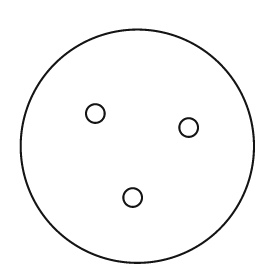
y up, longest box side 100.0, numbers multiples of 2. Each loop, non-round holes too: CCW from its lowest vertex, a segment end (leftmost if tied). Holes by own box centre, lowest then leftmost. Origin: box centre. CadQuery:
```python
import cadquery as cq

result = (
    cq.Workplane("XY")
    .moveTo(0.0, 0.0)
    .circle(50.0)
    .moveTo(-2.0, -22.0)
    .circle(4.0)
    .moveTo(22.0, 8.0)
    .circle(4.0)
    .moveTo(-18.0, 14.0)
    .circle(4.0)
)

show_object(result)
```